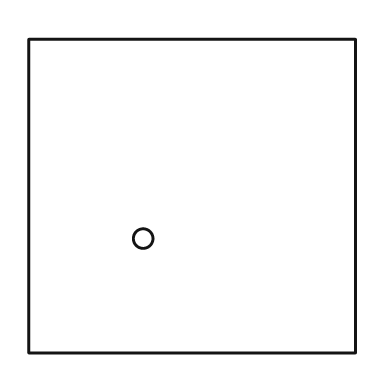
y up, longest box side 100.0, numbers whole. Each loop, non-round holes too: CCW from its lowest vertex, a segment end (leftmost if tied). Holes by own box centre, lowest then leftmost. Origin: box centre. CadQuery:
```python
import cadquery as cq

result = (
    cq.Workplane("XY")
    .moveTo(-50.0, -48.0)
    .lineTo(50.0, -48.0)
    .lineTo(50.0, 48.0)
    .lineTo(-50.0, 48.0)
    .close()
    .moveTo(-15.0, -13.0)
    .circle(3.0)
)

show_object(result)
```